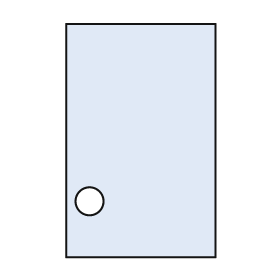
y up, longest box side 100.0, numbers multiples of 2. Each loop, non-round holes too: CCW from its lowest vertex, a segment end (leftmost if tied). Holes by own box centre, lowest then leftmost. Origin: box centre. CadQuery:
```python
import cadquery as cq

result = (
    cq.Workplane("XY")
    .moveTo(-32.0, -50.0)
    .lineTo(32.0, -50.0)
    .lineTo(32.0, 50.0)
    .lineTo(-32.0, 50.0)
    .close()
    .moveTo(-22.0, -26.0)
    .circle(6.0)
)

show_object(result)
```